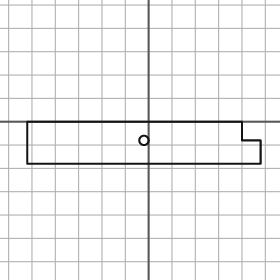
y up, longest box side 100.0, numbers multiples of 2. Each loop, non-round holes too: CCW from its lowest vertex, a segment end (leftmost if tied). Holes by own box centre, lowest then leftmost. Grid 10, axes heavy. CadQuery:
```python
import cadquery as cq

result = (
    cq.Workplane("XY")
    .moveTo(-52.0, -18.0)
    .lineTo(48.0, -18.0)
    .lineTo(48.0, -8.0)
    .lineTo(40.0, -8.0)
    .lineTo(40.0, 0.0)
    .lineTo(-52.0, 0.0)
    .close()
    .moveTo(-2.0, -8.0)
    .circle(2.0)
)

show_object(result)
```